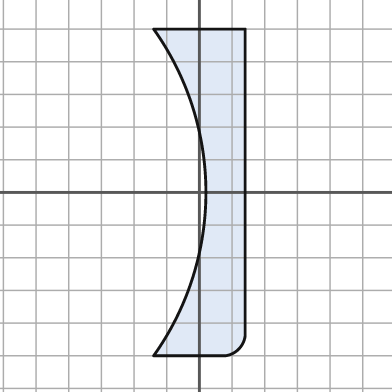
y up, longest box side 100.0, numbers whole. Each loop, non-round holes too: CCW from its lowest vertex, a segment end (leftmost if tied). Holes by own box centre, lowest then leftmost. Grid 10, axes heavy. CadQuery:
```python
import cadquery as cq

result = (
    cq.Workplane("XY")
    .moveTo(-14.0, -50.0)
    .lineTo(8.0, -50.0)
    .threePointArc((12.0, -48.0), (14.0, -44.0))
    .lineTo(14.0, 50.0)
    .lineTo(-14.0, 50.0)
    .threePointArc((2.0, 0.0), (-14.0, -50.0))
    .close()
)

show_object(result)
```